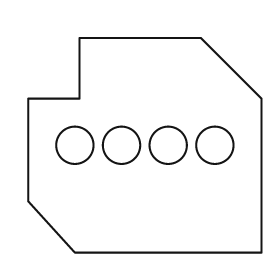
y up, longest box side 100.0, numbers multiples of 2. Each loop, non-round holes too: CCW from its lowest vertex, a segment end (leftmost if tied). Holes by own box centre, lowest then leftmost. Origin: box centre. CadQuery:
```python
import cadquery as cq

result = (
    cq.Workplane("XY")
    .moveTo(-30.0, -46.0)
    .lineTo(50.0, -46.0)
    .lineTo(50.0, 20.0)
    .lineTo(24.0, 46.0)
    .lineTo(-28.0, 46.0)
    .lineTo(-28.0, 20.0)
    .lineTo(-50.0, 20.0)
    .lineTo(-50.0, -24.0)
    .close()
    .moveTo(-30.0, 0.0)
    .circle(8.0)
    .moveTo(-10.0, 0.0)
    .circle(8.0)
    .moveTo(10.0, 0.0)
    .circle(8.0)
    .moveTo(30.0, 0.0)
    .circle(8.0)
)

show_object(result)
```